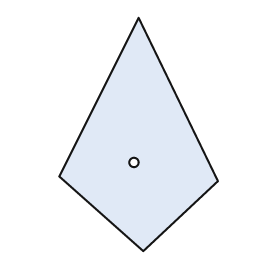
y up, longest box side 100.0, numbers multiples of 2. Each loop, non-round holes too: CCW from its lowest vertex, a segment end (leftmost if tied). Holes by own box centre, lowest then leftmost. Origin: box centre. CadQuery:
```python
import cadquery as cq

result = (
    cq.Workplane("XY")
    .moveTo(2.0, -50.0)
    .lineTo(34.0, -20.0)
    .lineTo(0.0, 50.0)
    .lineTo(-34.0, -18.0)
    .close()
    .moveTo(-2.0, -12.0)
    .circle(2.0)
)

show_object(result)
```